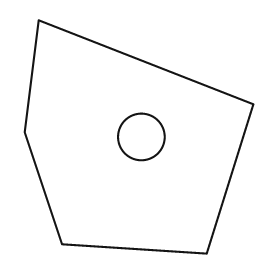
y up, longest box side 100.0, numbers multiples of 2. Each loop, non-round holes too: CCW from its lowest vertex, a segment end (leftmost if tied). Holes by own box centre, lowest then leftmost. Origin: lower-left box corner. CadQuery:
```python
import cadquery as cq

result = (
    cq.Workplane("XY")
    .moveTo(78.0, 0.0)
    .lineTo(98.0, 64.0)
    .lineTo(6.0, 100.0)
    .lineTo(0.0, 52.0)
    .lineTo(16.0, 4.0)
    .close()
    .moveTo(50.0, 50.0)
    .circle(10.0)
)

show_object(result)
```